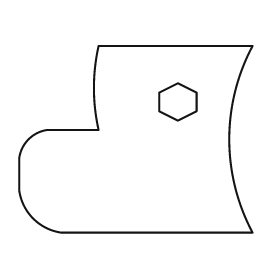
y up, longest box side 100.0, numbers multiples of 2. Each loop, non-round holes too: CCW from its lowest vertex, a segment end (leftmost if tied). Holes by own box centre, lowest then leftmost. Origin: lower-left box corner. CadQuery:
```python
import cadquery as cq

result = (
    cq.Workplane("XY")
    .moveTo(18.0, 0.0)
    .lineTo(100.0, 0.0)
    .threePointArc((90.0, 40.0), (100.0, 80.0))
    .lineTo(34.0, 80.0)
    .threePointArc((32.0, 62.0), (34.0, 44.0))
    .lineTo(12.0, 44.0)
    .threePointArc((4.0, 40.0), (0.0, 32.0))
    .lineTo(0.0, 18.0)
    .threePointArc((6.0, 6.0), (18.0, 0.0))
    .close()
    .moveTo(68.0, 48.0)
    .lineTo(76.0, 52.0)
    .lineTo(76.0, 60.0)
    .lineTo(68.0, 64.0)
    .lineTo(60.0, 60.0)
    .lineTo(60.0, 52.0)
    .close()
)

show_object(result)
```